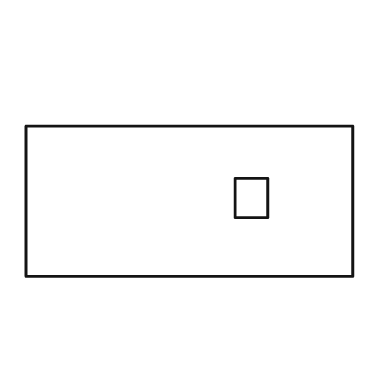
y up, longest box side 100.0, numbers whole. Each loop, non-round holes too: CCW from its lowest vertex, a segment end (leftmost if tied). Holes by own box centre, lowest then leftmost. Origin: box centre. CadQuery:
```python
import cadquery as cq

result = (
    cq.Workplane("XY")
    .moveTo(-50.0, -23.0)
    .lineTo(50.0, -23.0)
    .lineTo(50.0, 23.0)
    .lineTo(-50.0, 23.0)
    .close()
    .moveTo(14.0, -5.0)
    .lineTo(24.0, -5.0)
    .lineTo(24.0, 7.0)
    .lineTo(14.0, 7.0)
    .close()
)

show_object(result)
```